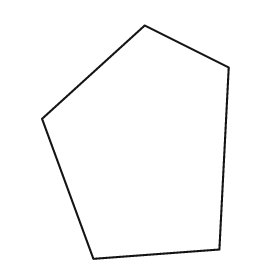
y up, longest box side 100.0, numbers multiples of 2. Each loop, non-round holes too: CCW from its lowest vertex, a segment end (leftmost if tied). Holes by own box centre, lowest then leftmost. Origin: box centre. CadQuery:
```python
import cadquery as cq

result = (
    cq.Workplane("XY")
    .moveTo(-18.0, -50.0)
    .lineTo(36.0, -46.0)
    .lineTo(40.0, 32.0)
    .lineTo(4.0, 50.0)
    .lineTo(-40.0, 10.0)
    .close()
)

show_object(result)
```